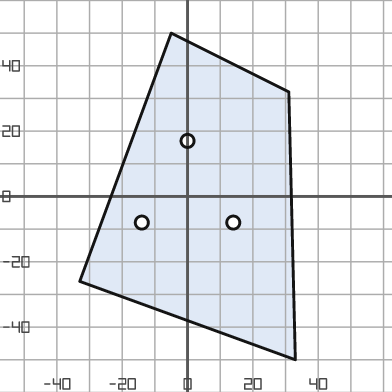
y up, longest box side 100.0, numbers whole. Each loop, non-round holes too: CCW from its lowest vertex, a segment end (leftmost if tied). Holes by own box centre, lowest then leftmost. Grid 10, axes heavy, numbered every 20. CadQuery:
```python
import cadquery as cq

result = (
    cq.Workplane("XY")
    .moveTo(33.0, -50.0)
    .lineTo(31.0, 32.0)
    .lineTo(-5.0, 50.0)
    .lineTo(-33.0, -26.0)
    .close()
    .moveTo(-14.0, -8.0)
    .circle(2.0)
    .moveTo(14.0, -8.0)
    .circle(2.0)
    .moveTo(0.0, 17.0)
    .circle(2.0)
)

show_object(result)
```